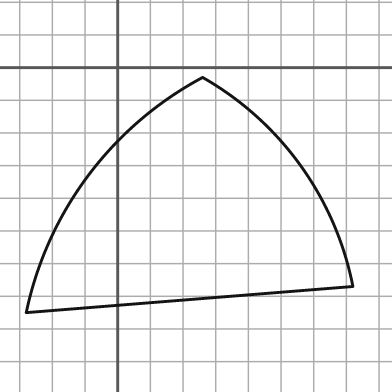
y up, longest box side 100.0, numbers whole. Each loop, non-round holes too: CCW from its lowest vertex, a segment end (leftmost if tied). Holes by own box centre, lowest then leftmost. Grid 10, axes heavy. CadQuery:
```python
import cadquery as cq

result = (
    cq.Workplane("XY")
    .moveTo(-28.0, -75.0)
    .lineTo(72.0, -67.0)
    .threePointArc((56.0, -30.0), (26.0, -3.0))
    .threePointArc((-9.0, -33.0), (-28.0, -75.0))
    .close()
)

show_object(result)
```